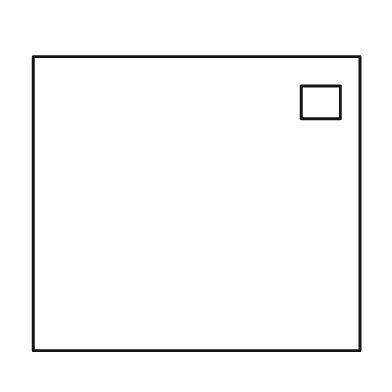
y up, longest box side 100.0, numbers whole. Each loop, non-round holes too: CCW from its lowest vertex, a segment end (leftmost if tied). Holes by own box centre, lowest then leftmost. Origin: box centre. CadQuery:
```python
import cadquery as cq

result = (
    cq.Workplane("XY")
    .moveTo(-50.0, -45.0)
    .lineTo(50.0, -45.0)
    .lineTo(50.0, 45.0)
    .lineTo(-50.0, 45.0)
    .close()
    .moveTo(32.0, 26.0)
    .lineTo(44.0, 26.0)
    .lineTo(44.0, 36.0)
    .lineTo(32.0, 36.0)
    .close()
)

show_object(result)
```